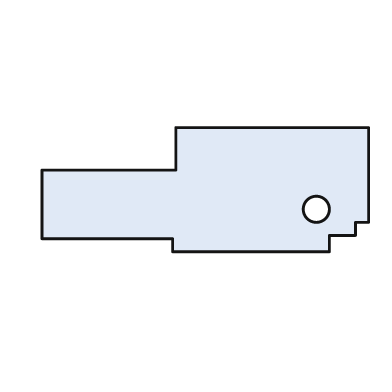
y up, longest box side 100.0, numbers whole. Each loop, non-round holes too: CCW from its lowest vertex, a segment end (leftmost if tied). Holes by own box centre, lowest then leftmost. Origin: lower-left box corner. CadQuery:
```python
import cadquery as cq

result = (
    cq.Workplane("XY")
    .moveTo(40.0, 0.0)
    .lineTo(88.0, 0.0)
    .lineTo(88.0, 5.0)
    .lineTo(96.0, 5.0)
    .lineTo(96.0, 9.0)
    .lineTo(100.0, 9.0)
    .lineTo(100.0, 38.0)
    .lineTo(41.0, 38.0)
    .lineTo(41.0, 25.0)
    .lineTo(0.0, 25.0)
    .lineTo(0.0, 4.0)
    .lineTo(40.0, 4.0)
    .close()
    .moveTo(84.0, 13.0)
    .circle(4.0)
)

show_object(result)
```